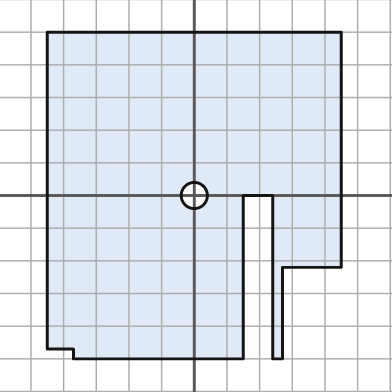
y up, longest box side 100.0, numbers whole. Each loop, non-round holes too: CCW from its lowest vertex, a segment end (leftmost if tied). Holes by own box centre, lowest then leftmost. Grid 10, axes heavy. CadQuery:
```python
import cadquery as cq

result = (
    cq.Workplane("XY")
    .moveTo(-37.0, -50.0)
    .lineTo(15.0, -50.0)
    .lineTo(15.0, 0.0)
    .lineTo(24.0, 0.0)
    .lineTo(24.0, -50.0)
    .lineTo(27.0, -50.0)
    .lineTo(27.0, -22.0)
    .lineTo(45.0, -22.0)
    .lineTo(45.0, 50.0)
    .lineTo(-45.0, 50.0)
    .lineTo(-45.0, -47.0)
    .lineTo(-37.0, -47.0)
    .close()
    .moveTo(0.0, 0.0)
    .circle(4.0)
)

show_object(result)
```